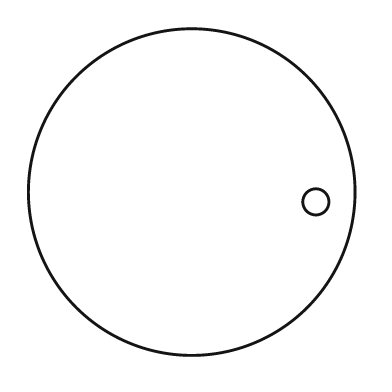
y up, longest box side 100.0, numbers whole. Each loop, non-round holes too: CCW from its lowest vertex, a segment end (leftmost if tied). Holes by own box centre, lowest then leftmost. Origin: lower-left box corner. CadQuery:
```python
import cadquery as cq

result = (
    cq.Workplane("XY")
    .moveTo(50.0, 50.0)
    .circle(50.0)
    .moveTo(88.0, 47.0)
    .circle(4.0)
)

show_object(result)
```